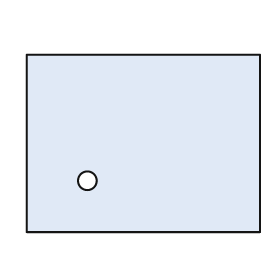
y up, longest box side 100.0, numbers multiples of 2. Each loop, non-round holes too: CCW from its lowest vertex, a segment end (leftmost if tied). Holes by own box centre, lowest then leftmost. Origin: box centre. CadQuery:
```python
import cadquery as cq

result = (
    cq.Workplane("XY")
    .moveTo(-50.0, -38.0)
    .lineTo(50.0, -38.0)
    .lineTo(50.0, 38.0)
    .lineTo(-50.0, 38.0)
    .close()
    .moveTo(-24.0, -16.0)
    .circle(4.0)
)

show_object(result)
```